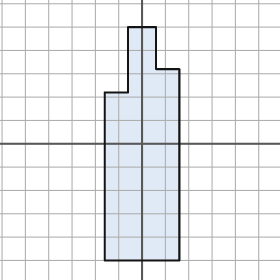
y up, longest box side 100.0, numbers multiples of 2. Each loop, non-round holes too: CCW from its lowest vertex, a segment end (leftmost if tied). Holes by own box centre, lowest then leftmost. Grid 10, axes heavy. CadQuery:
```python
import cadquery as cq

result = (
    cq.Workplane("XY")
    .moveTo(-16.0, -50.0)
    .lineTo(16.0, -50.0)
    .lineTo(16.0, 32.0)
    .lineTo(6.0, 32.0)
    .lineTo(6.0, 50.0)
    .lineTo(-6.0, 50.0)
    .lineTo(-6.0, 22.0)
    .lineTo(-16.0, 22.0)
    .close()
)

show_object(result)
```